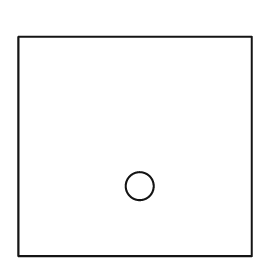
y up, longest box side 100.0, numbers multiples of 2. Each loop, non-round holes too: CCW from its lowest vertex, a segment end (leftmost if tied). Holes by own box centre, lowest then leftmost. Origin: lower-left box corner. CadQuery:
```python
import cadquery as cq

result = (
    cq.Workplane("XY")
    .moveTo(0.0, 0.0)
    .lineTo(100.0, 0.0)
    .lineTo(100.0, 94.0)
    .lineTo(0.0, 94.0)
    .close()
    .moveTo(52.0, 30.0)
    .circle(6.0)
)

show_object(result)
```